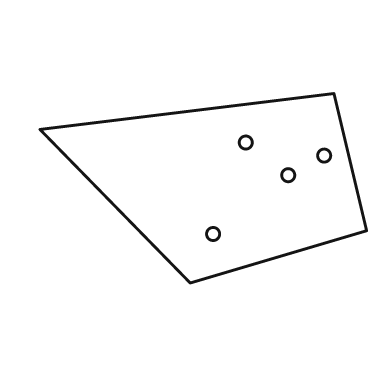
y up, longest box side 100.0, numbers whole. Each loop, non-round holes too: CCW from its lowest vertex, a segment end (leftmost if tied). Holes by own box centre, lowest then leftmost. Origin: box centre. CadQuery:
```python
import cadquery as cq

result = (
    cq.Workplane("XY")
    .moveTo(-4.0, -29.0)
    .lineTo(50.0, -13.0)
    .lineTo(40.0, 29.0)
    .lineTo(-50.0, 18.0)
    .close()
    .moveTo(3.0, -14.0)
    .circle(2.0)
    .moveTo(26.0, 4.0)
    .circle(2.0)
    .moveTo(37.0, 10.0)
    .circle(2.0)
    .moveTo(13.0, 14.0)
    .circle(2.0)
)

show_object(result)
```